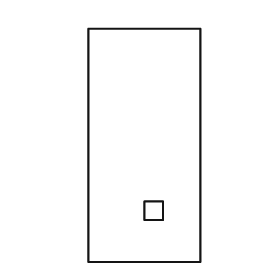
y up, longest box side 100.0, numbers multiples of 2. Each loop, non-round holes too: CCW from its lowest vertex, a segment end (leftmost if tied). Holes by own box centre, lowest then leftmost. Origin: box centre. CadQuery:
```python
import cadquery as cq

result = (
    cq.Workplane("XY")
    .moveTo(-24.0, -50.0)
    .lineTo(24.0, -50.0)
    .lineTo(24.0, 50.0)
    .lineTo(-24.0, 50.0)
    .close()
    .moveTo(0.0, -32.0)
    .lineTo(8.0, -32.0)
    .lineTo(8.0, -24.0)
    .lineTo(0.0, -24.0)
    .close()
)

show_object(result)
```